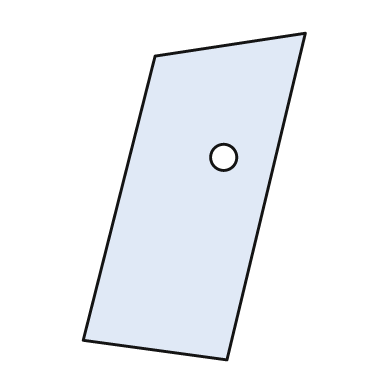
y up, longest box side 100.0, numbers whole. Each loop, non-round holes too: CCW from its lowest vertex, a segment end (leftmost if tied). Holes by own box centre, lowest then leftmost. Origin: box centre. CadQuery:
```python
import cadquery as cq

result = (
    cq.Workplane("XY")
    .moveTo(10.0, -50.0)
    .lineTo(34.0, 50.0)
    .lineTo(-12.0, 43.0)
    .lineTo(-34.0, -44.0)
    .close()
    .moveTo(9.0, 12.0)
    .circle(4.0)
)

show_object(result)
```